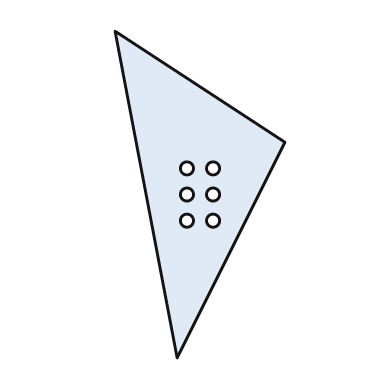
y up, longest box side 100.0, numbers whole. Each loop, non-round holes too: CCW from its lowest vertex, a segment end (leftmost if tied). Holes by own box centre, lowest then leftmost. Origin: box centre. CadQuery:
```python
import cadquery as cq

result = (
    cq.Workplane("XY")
    .moveTo(-7.0, -50.0)
    .lineTo(26.0, 16.0)
    .lineTo(-26.0, 50.0)
    .close()
    .moveTo(-4.0, -8.0)
    .circle(2.0)
    .moveTo(4.0, -8.0)
    .circle(2.0)
    .moveTo(-4.0, 0.0)
    .circle(2.0)
    .moveTo(4.0, 0.0)
    .circle(2.0)
    .moveTo(-4.0, 8.0)
    .circle(2.0)
    .moveTo(4.0, 8.0)
    .circle(2.0)
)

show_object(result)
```